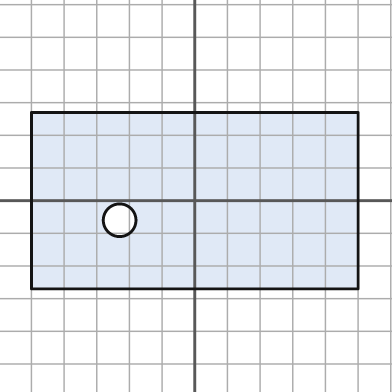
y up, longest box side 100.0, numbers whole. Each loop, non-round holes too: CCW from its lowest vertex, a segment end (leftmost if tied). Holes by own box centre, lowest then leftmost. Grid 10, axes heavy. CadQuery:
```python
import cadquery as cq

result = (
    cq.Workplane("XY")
    .moveTo(-50.0, -27.0)
    .lineTo(50.0, -27.0)
    .lineTo(50.0, 27.0)
    .lineTo(-50.0, 27.0)
    .close()
    .moveTo(-23.0, -6.0)
    .circle(5.0)
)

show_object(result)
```